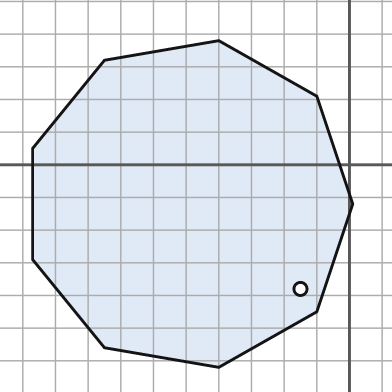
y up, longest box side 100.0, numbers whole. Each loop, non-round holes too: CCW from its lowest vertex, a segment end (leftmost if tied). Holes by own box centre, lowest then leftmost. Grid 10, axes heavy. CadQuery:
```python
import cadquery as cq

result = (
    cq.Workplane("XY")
    .moveTo(-40.0, -62.0)
    .lineTo(-10.0, -45.0)
    .lineTo(1.0, -12.0)
    .lineTo(-10.0, 21.0)
    .lineTo(-40.0, 38.0)
    .lineTo(-75.0, 32.0)
    .lineTo(-97.0, 5.0)
    .lineTo(-97.0, -29.0)
    .lineTo(-75.0, -56.0)
    .close()
    .moveTo(-15.0, -38.0)
    .circle(2.0)
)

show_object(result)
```